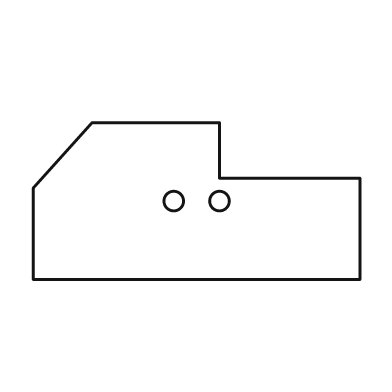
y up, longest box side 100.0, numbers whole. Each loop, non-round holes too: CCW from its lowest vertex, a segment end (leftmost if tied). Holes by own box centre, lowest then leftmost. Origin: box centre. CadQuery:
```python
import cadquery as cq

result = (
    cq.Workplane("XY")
    .moveTo(-50.0, -24.0)
    .lineTo(50.0, -24.0)
    .lineTo(50.0, 7.0)
    .lineTo(7.0, 7.0)
    .lineTo(7.0, 24.0)
    .lineTo(-32.0, 24.0)
    .lineTo(-50.0, 4.0)
    .close()
    .moveTo(-7.0, 0.0)
    .circle(3.0)
    .moveTo(7.0, 0.0)
    .circle(3.0)
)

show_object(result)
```